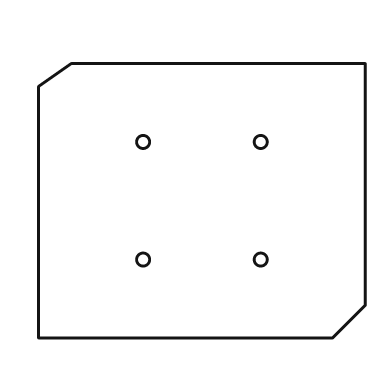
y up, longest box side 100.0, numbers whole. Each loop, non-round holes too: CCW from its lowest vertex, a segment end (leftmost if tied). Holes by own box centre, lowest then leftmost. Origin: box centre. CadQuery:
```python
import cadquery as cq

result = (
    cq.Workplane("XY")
    .moveTo(-50.0, -42.0)
    .lineTo(40.0, -42.0)
    .lineTo(50.0, -32.0)
    .lineTo(50.0, 42.0)
    .lineTo(-40.0, 42.0)
    .lineTo(-50.0, 35.0)
    .close()
    .moveTo(-18.0, -18.0)
    .circle(2.0)
    .moveTo(18.0, -18.0)
    .circle(2.0)
    .moveTo(-18.0, 18.0)
    .circle(2.0)
    .moveTo(18.0, 18.0)
    .circle(2.0)
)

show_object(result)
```